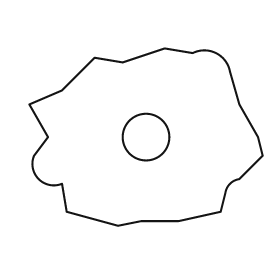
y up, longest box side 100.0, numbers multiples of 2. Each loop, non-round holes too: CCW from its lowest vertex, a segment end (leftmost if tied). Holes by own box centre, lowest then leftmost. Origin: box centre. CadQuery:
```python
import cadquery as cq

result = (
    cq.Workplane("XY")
    .moveTo(-12.0, -38.0)
    .lineTo(-2.0, -36.0)
    .lineTo(14.0, -36.0)
    .lineTo(32.0, -32.0)
    .lineTo(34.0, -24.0)
    .threePointArc((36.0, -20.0), (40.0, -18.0))
    .lineTo(50.0, -8.0)
    .lineTo(48.0, 0.0)
    .lineTo(40.0, 14.0)
    .lineTo(36.0, 28.0)
    .threePointArc((30.0, 36.0), (20.0, 36.0))
    .lineTo(8.0, 38.0)
    .lineTo(-10.0, 32.0)
    .lineTo(-22.0, 34.0)
    .lineTo(-36.0, 20.0)
    .lineTo(-50.0, 14.0)
    .lineTo(-42.0, 0.0)
    .lineTo(-48.0, -8.0)
    .threePointArc((-46.0, -18.0), (-36.0, -20.0))
    .lineTo(-34.0, -32.0)
    .close()
    .moveTo(0.0, 0.0)
    .circle(10.0)
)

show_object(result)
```